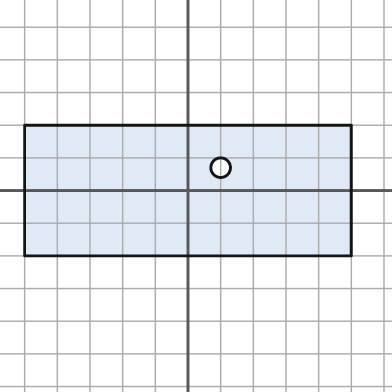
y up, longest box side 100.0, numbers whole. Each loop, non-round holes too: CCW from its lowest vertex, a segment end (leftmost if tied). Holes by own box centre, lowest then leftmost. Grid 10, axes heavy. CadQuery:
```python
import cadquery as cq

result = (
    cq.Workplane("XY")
    .moveTo(-50.0, -20.0)
    .lineTo(50.0, -20.0)
    .lineTo(50.0, 20.0)
    .lineTo(-50.0, 20.0)
    .close()
    .moveTo(10.0, 7.0)
    .circle(3.0)
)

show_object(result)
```